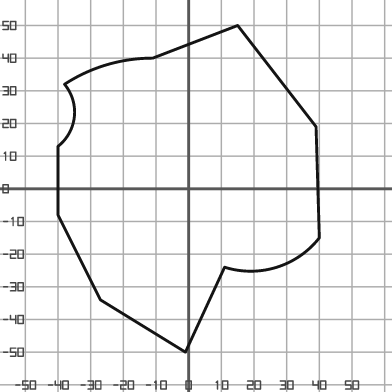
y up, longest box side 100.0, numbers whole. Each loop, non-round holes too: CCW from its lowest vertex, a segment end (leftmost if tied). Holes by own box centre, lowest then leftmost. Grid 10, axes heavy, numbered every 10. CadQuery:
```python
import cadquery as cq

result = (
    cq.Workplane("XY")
    .moveTo(-1.0, -50.0)
    .lineTo(11.0, -24.0)
    .threePointArc((27.0, -24.0), (40.0, -15.0))
    .lineTo(39.0, 19.0)
    .lineTo(15.0, 50.0)
    .lineTo(-11.0, 40.0)
    .threePointArc((-25.0, 38.0), (-38.0, 32.0))
    .threePointArc((-35.0, 22.0), (-40.0, 13.0))
    .lineTo(-40.0, -8.0)
    .lineTo(-27.0, -34.0)
    .close()
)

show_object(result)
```